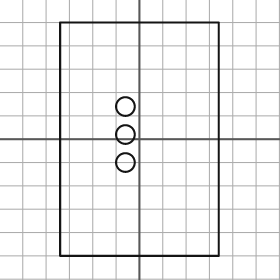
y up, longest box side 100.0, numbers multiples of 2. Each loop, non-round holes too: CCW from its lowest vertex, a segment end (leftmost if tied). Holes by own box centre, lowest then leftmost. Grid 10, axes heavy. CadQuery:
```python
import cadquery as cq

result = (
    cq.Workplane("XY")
    .moveTo(-34.0, -50.0)
    .lineTo(34.0, -50.0)
    .lineTo(34.0, 50.0)
    .lineTo(-34.0, 50.0)
    .close()
    .moveTo(-6.0, -10.0)
    .circle(4.0)
    .moveTo(-6.0, 2.0)
    .circle(4.0)
    .moveTo(-6.0, 14.0)
    .circle(4.0)
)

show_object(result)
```